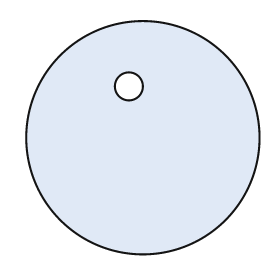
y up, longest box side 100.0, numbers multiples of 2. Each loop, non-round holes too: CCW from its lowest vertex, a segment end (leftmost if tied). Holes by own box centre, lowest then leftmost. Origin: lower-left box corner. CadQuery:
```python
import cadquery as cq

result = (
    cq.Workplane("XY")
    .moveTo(50.0, 50.0)
    .circle(50.0)
    .moveTo(44.0, 72.0)
    .circle(6.0)
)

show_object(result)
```